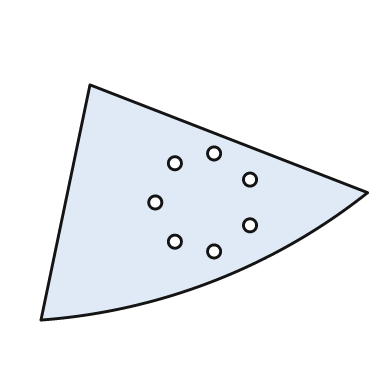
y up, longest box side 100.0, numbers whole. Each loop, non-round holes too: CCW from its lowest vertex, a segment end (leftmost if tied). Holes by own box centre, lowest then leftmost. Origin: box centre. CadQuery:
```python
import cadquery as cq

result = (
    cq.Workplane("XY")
    .moveTo(-50.0, -36.0)
    .threePointArc((3.0, -24.0), (50.0, 3.0))
    .lineTo(-35.0, 36.0)
    .close()
    .moveTo(3.0, -15.0)
    .circle(2.0)
    .moveTo(-9.0, -12.0)
    .circle(2.0)
    .moveTo(14.0, -7.0)
    .circle(2.0)
    .moveTo(-15.0, 0.0)
    .circle(2.0)
    .moveTo(14.0, 7.0)
    .circle(2.0)
    .moveTo(-9.0, 12.0)
    .circle(2.0)
    .moveTo(3.0, 15.0)
    .circle(2.0)
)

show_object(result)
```